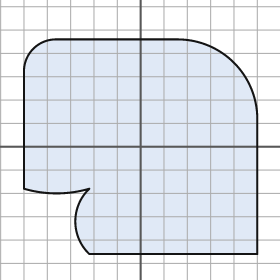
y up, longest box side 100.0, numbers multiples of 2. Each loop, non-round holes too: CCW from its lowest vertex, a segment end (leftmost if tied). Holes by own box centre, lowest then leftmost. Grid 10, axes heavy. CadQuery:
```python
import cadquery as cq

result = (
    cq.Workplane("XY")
    .moveTo(-22.0, -46.0)
    .lineTo(50.0, -46.0)
    .lineTo(50.0, 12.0)
    .threePointArc((40.0, 36.0), (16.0, 46.0))
    .lineTo(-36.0, 46.0)
    .threePointArc((-46.0, 42.0), (-50.0, 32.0))
    .lineTo(-50.0, -18.0)
    .threePointArc((-36.0, -20.0), (-22.0, -18.0))
    .threePointArc((-28.0, -32.0), (-22.0, -46.0))
    .close()
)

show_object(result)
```